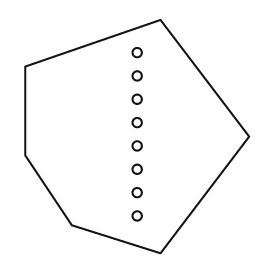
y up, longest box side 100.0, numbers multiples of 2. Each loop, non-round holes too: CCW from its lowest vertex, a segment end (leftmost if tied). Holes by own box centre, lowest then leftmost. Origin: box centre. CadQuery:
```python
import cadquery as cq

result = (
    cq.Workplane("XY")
    .moveTo(10.0, -50.0)
    .lineTo(48.0, 0.0)
    .lineTo(10.0, 50.0)
    .lineTo(-48.0, 30.0)
    .lineTo(-48.0, -8.0)
    .lineTo(-28.0, -38.0)
    .close()
    .moveTo(0.0, -34.0)
    .circle(2.0)
    .moveTo(0.0, -24.0)
    .circle(2.0)
    .moveTo(0.0, -14.0)
    .circle(2.0)
    .moveTo(0.0, -4.0)
    .circle(2.0)
    .moveTo(0.0, 6.0)
    .circle(2.0)
    .moveTo(0.0, 16.0)
    .circle(2.0)
    .moveTo(0.0, 26.0)
    .circle(2.0)
    .moveTo(0.0, 36.0)
    .circle(2.0)
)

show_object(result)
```